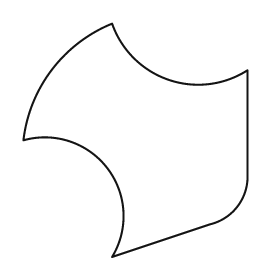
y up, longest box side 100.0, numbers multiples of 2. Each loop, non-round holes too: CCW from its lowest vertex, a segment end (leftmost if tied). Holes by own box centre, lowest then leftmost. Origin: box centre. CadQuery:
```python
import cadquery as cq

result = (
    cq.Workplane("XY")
    .moveTo(-10.0, -50.0)
    .lineTo(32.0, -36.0)
    .threePointArc((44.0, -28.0), (48.0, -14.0))
    .lineTo(48.0, 30.0)
    .threePointArc((14.0, 26.0), (-10.0, 50.0))
    .threePointArc((-36.0, 30.0), (-48.0, 0.0))
    .threePointArc((-12.0, -12.0), (-10.0, -50.0))
    .close()
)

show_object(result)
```